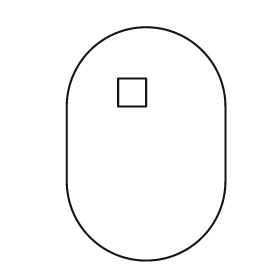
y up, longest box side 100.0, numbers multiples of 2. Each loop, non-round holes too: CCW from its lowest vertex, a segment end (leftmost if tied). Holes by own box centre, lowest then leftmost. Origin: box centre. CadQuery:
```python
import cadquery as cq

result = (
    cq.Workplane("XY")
    .moveTo(-34.0, -16.0)
    .threePointArc((0.0, -50.0), (34.0, -16.0))
    .lineTo(34.0, 16.0)
    .threePointArc((0.0, 50.0), (-34.0, 16.0))
    .close()
    .moveTo(-12.0, 16.0)
    .lineTo(0.0, 16.0)
    .lineTo(0.0, 28.0)
    .lineTo(-12.0, 28.0)
    .close()
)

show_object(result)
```